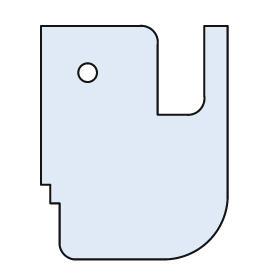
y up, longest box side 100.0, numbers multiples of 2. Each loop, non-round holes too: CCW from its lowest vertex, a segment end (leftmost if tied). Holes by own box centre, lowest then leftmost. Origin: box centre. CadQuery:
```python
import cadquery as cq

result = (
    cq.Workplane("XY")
    .moveTo(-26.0, -50.0)
    .lineTo(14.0, -50.0)
    .threePointArc((32.0, -42.0), (40.0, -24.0))
    .lineTo(40.0, 50.0)
    .lineTo(30.0, 50.0)
    .lineTo(30.0, 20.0)
    .threePointArc((28.0, 14.0), (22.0, 12.0))
    .lineTo(10.0, 12.0)
    .lineTo(10.0, 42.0)
    .threePointArc((8.0, 48.0), (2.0, 50.0))
    .lineTo(-40.0, 50.0)
    .lineTo(-40.0, -18.0)
    .lineTo(-36.0, -18.0)
    .lineTo(-36.0, -26.0)
    .lineTo(-32.0, -26.0)
    .lineTo(-32.0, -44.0)
    .threePointArc((-30.0, -48.0), (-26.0, -50.0))
    .close()
    .moveTo(-20.0, 30.0)
    .circle(4.0)
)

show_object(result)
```